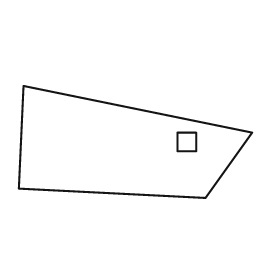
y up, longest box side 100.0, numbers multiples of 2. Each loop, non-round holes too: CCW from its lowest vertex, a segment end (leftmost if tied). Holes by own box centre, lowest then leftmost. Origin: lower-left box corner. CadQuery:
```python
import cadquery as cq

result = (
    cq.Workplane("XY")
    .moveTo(80.0, 0.0)
    .lineTo(100.0, 28.0)
    .lineTo(2.0, 48.0)
    .lineTo(0.0, 4.0)
    .close()
    .moveTo(68.0, 20.0)
    .lineTo(76.0, 20.0)
    .lineTo(76.0, 28.0)
    .lineTo(68.0, 28.0)
    .close()
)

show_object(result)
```